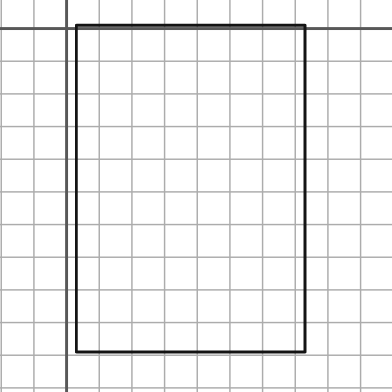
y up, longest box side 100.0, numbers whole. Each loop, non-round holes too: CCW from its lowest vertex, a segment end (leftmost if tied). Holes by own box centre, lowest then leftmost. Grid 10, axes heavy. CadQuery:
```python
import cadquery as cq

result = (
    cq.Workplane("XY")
    .moveTo(3.0, -99.0)
    .lineTo(73.0, -99.0)
    .lineTo(73.0, 1.0)
    .lineTo(3.0, 1.0)
    .close()
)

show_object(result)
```